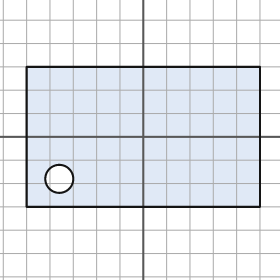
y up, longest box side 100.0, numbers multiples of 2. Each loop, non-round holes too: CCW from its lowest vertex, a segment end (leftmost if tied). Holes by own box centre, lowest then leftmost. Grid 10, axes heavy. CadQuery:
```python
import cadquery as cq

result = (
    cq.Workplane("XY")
    .moveTo(-50.0, -30.0)
    .lineTo(50.0, -30.0)
    .lineTo(50.0, 30.0)
    .lineTo(-50.0, 30.0)
    .close()
    .moveTo(-36.0, -18.0)
    .circle(6.0)
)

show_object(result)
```